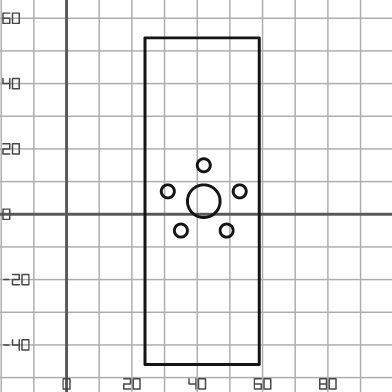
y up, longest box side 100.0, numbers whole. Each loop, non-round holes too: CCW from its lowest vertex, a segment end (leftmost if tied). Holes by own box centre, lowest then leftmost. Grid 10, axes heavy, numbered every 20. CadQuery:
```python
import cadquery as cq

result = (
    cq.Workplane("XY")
    .moveTo(24.0, -46.0)
    .lineTo(59.0, -46.0)
    .lineTo(59.0, 54.0)
    .lineTo(24.0, 54.0)
    .close()
    .moveTo(35.0, -5.0)
    .circle(2.0)
    .moveTo(49.0, -5.0)
    .circle(2.0)
    .moveTo(42.0, 4.0)
    .circle(5.0)
    .moveTo(31.0, 7.0)
    .circle(2.0)
    .moveTo(53.0, 7.0)
    .circle(2.0)
    .moveTo(42.0, 15.0)
    .circle(2.0)
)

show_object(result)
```